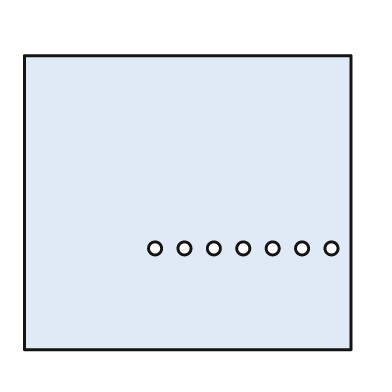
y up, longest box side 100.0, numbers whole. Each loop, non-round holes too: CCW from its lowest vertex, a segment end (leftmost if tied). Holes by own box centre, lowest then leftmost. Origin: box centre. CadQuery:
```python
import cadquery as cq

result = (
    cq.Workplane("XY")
    .moveTo(-50.0, -45.0)
    .lineTo(50.0, -45.0)
    .lineTo(50.0, 45.0)
    .lineTo(-50.0, 45.0)
    .close()
    .moveTo(-10.0, -14.0)
    .circle(2.0)
    .moveTo(-1.0, -14.0)
    .circle(2.0)
    .moveTo(8.0, -14.0)
    .circle(2.0)
    .moveTo(17.0, -14.0)
    .circle(2.0)
    .moveTo(26.0, -14.0)
    .circle(2.0)
    .moveTo(35.0, -14.0)
    .circle(2.0)
    .moveTo(44.0, -14.0)
    .circle(2.0)
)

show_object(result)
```